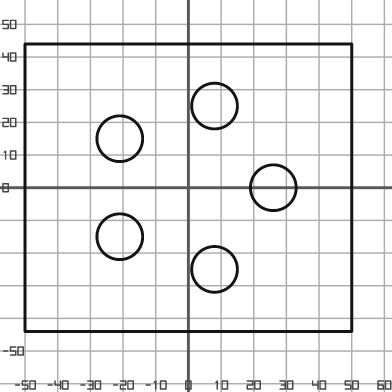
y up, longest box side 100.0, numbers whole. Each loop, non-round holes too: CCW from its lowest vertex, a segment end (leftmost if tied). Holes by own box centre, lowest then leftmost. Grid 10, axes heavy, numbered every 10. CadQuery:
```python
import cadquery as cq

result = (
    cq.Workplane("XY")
    .moveTo(-50.0, -44.0)
    .lineTo(50.0, -44.0)
    .lineTo(50.0, 44.0)
    .lineTo(-50.0, 44.0)
    .close()
    .moveTo(8.0, -25.0)
    .circle(7.0)
    .moveTo(-21.0, -15.0)
    .circle(7.0)
    .moveTo(26.0, 0.0)
    .circle(7.0)
    .moveTo(-21.0, 15.0)
    .circle(7.0)
    .moveTo(8.0, 25.0)
    .circle(7.0)
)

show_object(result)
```